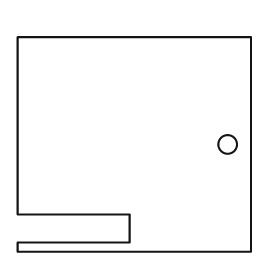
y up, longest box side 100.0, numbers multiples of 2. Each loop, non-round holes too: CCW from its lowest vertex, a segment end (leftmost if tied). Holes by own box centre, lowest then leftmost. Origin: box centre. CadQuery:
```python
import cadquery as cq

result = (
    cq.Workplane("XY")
    .moveTo(-50.0, -46.0)
    .lineTo(50.0, -46.0)
    .lineTo(50.0, 46.0)
    .lineTo(-50.0, 46.0)
    .lineTo(-50.0, -30.0)
    .lineTo(-2.0, -30.0)
    .lineTo(-2.0, -42.0)
    .lineTo(-50.0, -42.0)
    .close()
    .moveTo(40.0, 0.0)
    .circle(4.0)
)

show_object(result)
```